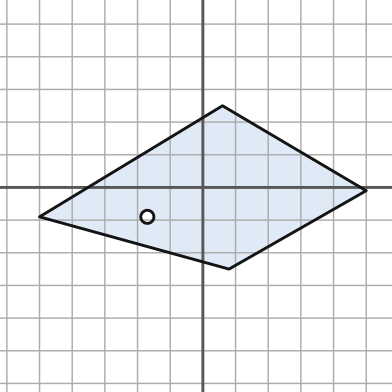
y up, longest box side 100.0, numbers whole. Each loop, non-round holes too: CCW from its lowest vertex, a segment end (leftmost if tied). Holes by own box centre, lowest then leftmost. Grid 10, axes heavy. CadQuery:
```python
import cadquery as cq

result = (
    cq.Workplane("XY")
    .moveTo(8.0, -25.0)
    .lineTo(50.0, -1.0)
    .lineTo(6.0, 25.0)
    .lineTo(-50.0, -9.0)
    .close()
    .moveTo(-17.0, -9.0)
    .circle(2.0)
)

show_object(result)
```